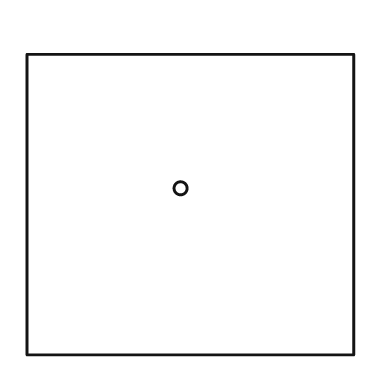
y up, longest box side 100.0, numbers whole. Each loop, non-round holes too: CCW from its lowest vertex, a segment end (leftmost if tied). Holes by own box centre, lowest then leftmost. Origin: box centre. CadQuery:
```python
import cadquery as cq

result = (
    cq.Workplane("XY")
    .moveTo(-50.0, -46.0)
    .lineTo(50.0, -46.0)
    .lineTo(50.0, 46.0)
    .lineTo(-50.0, 46.0)
    .close()
    .moveTo(-3.0, 5.0)
    .circle(2.0)
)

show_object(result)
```